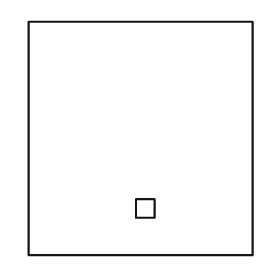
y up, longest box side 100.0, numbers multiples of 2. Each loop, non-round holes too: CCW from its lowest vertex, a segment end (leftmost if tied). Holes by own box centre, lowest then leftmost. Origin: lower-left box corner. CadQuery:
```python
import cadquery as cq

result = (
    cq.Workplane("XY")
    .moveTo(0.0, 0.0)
    .lineTo(96.0, 0.0)
    .lineTo(96.0, 100.0)
    .lineTo(0.0, 100.0)
    .close()
    .moveTo(46.0, 16.0)
    .lineTo(54.0, 16.0)
    .lineTo(54.0, 24.0)
    .lineTo(46.0, 24.0)
    .close()
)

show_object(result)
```